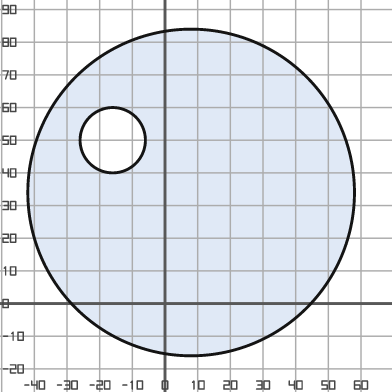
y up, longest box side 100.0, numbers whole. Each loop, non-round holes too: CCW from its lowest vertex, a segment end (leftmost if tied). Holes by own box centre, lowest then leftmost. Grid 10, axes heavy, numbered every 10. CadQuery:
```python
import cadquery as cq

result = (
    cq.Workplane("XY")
    .moveTo(8.0, 34.0)
    .circle(50.0)
    .moveTo(-16.0, 50.0)
    .circle(10.0)
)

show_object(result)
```